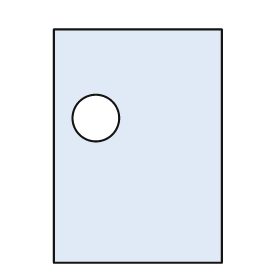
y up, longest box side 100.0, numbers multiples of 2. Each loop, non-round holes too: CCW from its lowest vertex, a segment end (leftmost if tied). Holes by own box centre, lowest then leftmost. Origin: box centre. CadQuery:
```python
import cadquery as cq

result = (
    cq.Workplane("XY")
    .moveTo(-36.0, -50.0)
    .lineTo(36.0, -50.0)
    .lineTo(36.0, 50.0)
    .lineTo(-36.0, 50.0)
    .close()
    .moveTo(-18.0, 12.0)
    .circle(10.0)
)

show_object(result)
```